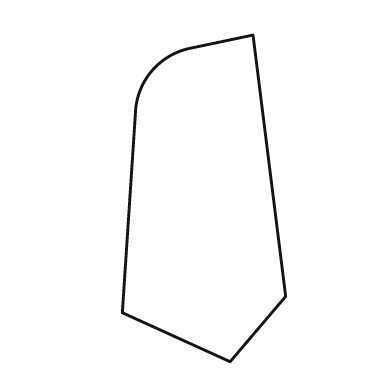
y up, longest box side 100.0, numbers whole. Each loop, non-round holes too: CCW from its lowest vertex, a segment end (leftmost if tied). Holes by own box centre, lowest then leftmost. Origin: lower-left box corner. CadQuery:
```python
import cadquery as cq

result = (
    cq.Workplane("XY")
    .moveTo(33.0, 0.0)
    .lineTo(50.0, 20.0)
    .lineTo(40.0, 100.0)
    .lineTo(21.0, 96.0)
    .threePointArc((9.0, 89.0), (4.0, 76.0))
    .lineTo(0.0, 15.0)
    .close()
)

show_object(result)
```